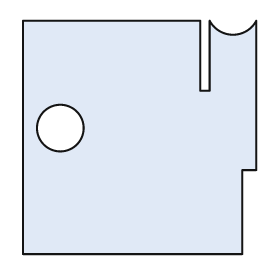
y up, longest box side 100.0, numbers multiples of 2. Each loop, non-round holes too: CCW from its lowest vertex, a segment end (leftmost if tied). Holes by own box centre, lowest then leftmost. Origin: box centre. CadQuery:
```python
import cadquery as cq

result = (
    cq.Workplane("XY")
    .moveTo(-50.0, -50.0)
    .lineTo(44.0, -50.0)
    .lineTo(44.0, -14.0)
    .lineTo(50.0, -14.0)
    .lineTo(50.0, 50.0)
    .threePointArc((40.0, 44.0), (30.0, 50.0))
    .lineTo(30.0, 20.0)
    .lineTo(26.0, 20.0)
    .lineTo(26.0, 50.0)
    .lineTo(-50.0, 50.0)
    .close()
    .moveTo(-34.0, 4.0)
    .circle(10.0)
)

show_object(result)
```